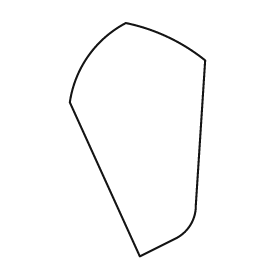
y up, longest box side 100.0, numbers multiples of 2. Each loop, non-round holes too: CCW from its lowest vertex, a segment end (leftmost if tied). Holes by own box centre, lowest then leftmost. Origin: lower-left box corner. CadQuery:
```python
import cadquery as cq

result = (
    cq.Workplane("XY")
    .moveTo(30.0, 0.0)
    .lineTo(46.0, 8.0)
    .threePointArc((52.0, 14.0), (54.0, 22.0))
    .lineTo(58.0, 84.0)
    .threePointArc((42.0, 94.0), (24.0, 100.0))
    .threePointArc((8.0, 86.0), (0.0, 66.0))
    .close()
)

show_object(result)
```